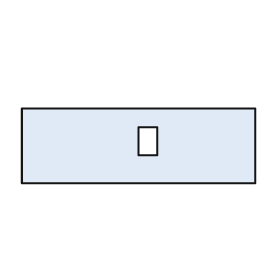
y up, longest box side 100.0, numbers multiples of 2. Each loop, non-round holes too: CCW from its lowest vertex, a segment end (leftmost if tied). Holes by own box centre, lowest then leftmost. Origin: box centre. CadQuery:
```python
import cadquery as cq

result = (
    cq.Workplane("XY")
    .moveTo(-50.0, -16.0)
    .lineTo(50.0, -16.0)
    .lineTo(50.0, 16.0)
    .lineTo(-50.0, 16.0)
    .close()
    .moveTo(0.0, -4.0)
    .lineTo(8.0, -4.0)
    .lineTo(8.0, 8.0)
    .lineTo(0.0, 8.0)
    .close()
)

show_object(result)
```